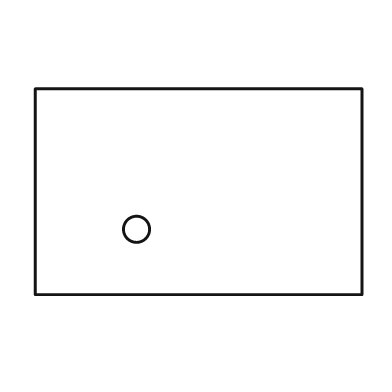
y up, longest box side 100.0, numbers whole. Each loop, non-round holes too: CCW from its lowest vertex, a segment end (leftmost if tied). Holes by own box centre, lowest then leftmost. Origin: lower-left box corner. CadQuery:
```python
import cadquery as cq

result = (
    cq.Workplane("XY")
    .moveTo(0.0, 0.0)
    .lineTo(100.0, 0.0)
    .lineTo(100.0, 63.0)
    .lineTo(0.0, 63.0)
    .close()
    .moveTo(31.0, 20.0)
    .circle(4.0)
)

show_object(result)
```